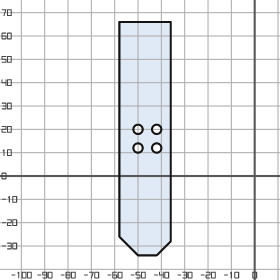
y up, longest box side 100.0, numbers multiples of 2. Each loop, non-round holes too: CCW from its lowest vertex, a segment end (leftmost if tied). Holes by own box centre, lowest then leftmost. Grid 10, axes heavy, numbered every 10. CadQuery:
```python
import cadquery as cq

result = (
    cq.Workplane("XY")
    .moveTo(-50.0, -34.0)
    .lineTo(-42.0, -34.0)
    .lineTo(-36.0, -28.0)
    .lineTo(-36.0, 66.0)
    .lineTo(-58.0, 66.0)
    .lineTo(-58.0, -26.0)
    .close()
    .moveTo(-50.0, 12.0)
    .circle(2.0)
    .moveTo(-42.0, 12.0)
    .circle(2.0)
    .moveTo(-50.0, 20.0)
    .circle(2.0)
    .moveTo(-42.0, 20.0)
    .circle(2.0)
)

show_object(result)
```